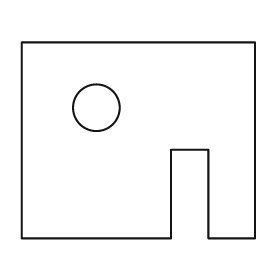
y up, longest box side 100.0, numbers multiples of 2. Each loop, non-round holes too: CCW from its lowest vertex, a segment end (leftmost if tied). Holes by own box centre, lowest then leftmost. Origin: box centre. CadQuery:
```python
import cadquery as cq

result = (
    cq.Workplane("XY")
    .moveTo(-50.0, -42.0)
    .lineTo(14.0, -42.0)
    .lineTo(14.0, -4.0)
    .lineTo(30.0, -4.0)
    .lineTo(30.0, -42.0)
    .lineTo(50.0, -42.0)
    .lineTo(50.0, 42.0)
    .lineTo(-50.0, 42.0)
    .close()
    .moveTo(-18.0, 14.0)
    .circle(10.0)
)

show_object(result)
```